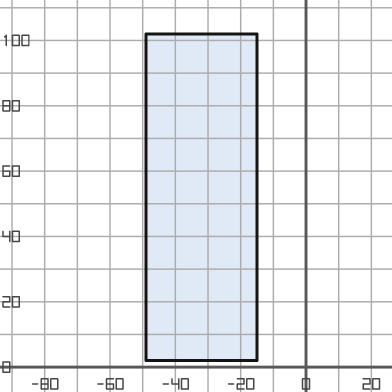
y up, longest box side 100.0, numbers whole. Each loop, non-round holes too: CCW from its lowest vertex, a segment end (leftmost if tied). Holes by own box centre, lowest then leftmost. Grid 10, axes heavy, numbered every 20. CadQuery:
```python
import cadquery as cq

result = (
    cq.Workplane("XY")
    .moveTo(-49.0, 2.0)
    .lineTo(-15.0, 2.0)
    .lineTo(-15.0, 102.0)
    .lineTo(-49.0, 102.0)
    .close()
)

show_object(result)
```